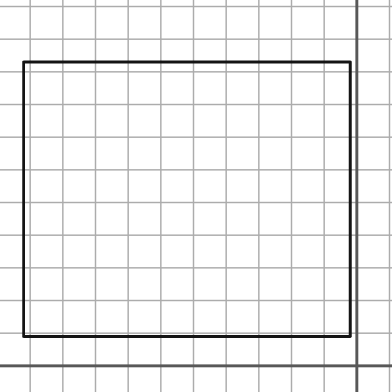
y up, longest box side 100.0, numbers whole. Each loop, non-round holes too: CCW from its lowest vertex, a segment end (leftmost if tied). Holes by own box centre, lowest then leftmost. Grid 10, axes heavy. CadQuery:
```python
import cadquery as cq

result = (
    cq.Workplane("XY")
    .moveTo(-102.0, 9.0)
    .lineTo(-2.0, 9.0)
    .lineTo(-2.0, 93.0)
    .lineTo(-102.0, 93.0)
    .close()
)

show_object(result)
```